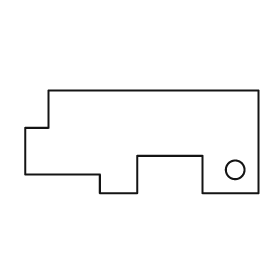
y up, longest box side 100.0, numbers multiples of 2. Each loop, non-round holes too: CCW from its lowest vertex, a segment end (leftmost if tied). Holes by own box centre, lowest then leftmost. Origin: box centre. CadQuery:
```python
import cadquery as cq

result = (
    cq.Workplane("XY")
    .moveTo(-18.0, -22.0)
    .lineTo(-2.0, -22.0)
    .lineTo(-2.0, -6.0)
    .lineTo(26.0, -6.0)
    .lineTo(26.0, -22.0)
    .lineTo(50.0, -22.0)
    .lineTo(50.0, 22.0)
    .lineTo(-40.0, 22.0)
    .lineTo(-40.0, 6.0)
    .lineTo(-50.0, 6.0)
    .lineTo(-50.0, -14.0)
    .lineTo(-18.0, -14.0)
    .close()
    .moveTo(40.0, -12.0)
    .circle(4.0)
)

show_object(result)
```